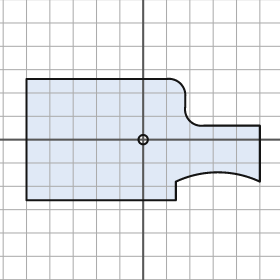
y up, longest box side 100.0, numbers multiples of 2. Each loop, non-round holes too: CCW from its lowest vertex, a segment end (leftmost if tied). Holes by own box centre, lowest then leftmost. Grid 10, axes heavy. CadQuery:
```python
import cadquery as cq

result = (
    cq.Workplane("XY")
    .moveTo(-50.0, -26.0)
    .lineTo(14.0, -26.0)
    .lineTo(14.0, -18.0)
    .threePointArc((32.0, -14.0), (50.0, -18.0))
    .lineTo(50.0, 6.0)
    .lineTo(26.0, 6.0)
    .threePointArc((20.0, 8.0), (18.0, 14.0))
    .lineTo(18.0, 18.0)
    .threePointArc((16.0, 24.0), (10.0, 26.0))
    .lineTo(-50.0, 26.0)
    .close()
    .moveTo(0.0, 0.0)
    .circle(2.0)
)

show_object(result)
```